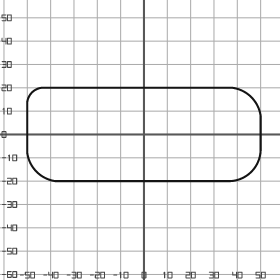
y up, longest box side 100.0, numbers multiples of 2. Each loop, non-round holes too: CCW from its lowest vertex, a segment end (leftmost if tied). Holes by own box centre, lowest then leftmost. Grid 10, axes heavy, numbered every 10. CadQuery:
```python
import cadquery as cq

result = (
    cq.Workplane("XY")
    .moveTo(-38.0, -20.0)
    .lineTo(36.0, -20.0)
    .threePointArc((46.0, -16.0), (50.0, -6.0))
    .lineTo(50.0, 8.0)
    .threePointArc((46.0, 16.0), (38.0, 20.0))
    .lineTo(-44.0, 20.0)
    .threePointArc((-48.0, 18.0), (-50.0, 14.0))
    .lineTo(-50.0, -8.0)
    .threePointArc((-46.0, -16.0), (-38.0, -20.0))
    .close()
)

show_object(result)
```